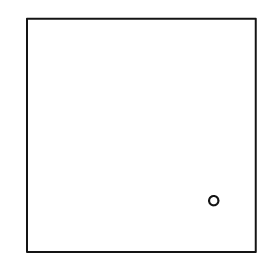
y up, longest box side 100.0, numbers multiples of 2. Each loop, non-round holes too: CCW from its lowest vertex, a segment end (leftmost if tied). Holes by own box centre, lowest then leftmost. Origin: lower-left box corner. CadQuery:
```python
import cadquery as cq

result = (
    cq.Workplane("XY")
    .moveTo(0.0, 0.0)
    .lineTo(98.0, 0.0)
    .lineTo(98.0, 100.0)
    .lineTo(0.0, 100.0)
    .close()
    .moveTo(80.0, 22.0)
    .circle(2.0)
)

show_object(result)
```